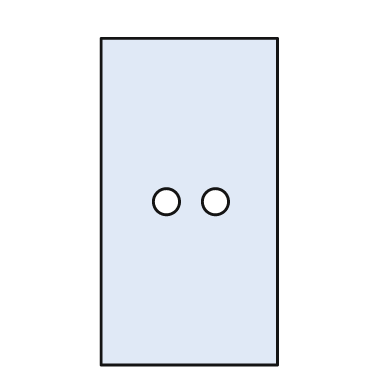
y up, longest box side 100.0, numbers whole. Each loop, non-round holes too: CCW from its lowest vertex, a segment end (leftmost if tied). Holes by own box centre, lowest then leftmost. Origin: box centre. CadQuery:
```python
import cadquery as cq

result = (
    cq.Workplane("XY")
    .moveTo(-27.0, -50.0)
    .lineTo(27.0, -50.0)
    .lineTo(27.0, 50.0)
    .lineTo(-27.0, 50.0)
    .close()
    .moveTo(-7.0, 0.0)
    .circle(4.0)
    .moveTo(8.0, 0.0)
    .circle(4.0)
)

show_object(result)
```